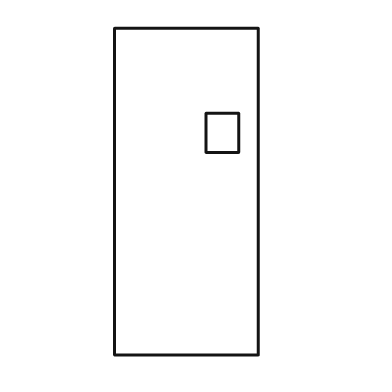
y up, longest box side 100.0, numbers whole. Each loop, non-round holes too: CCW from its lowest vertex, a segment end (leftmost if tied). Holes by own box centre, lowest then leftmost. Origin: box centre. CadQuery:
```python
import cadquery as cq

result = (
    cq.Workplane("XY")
    .moveTo(-22.0, -50.0)
    .lineTo(22.0, -50.0)
    .lineTo(22.0, 50.0)
    .lineTo(-22.0, 50.0)
    .close()
    .moveTo(6.0, 12.0)
    .lineTo(16.0, 12.0)
    .lineTo(16.0, 24.0)
    .lineTo(6.0, 24.0)
    .close()
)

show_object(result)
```